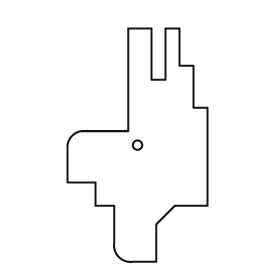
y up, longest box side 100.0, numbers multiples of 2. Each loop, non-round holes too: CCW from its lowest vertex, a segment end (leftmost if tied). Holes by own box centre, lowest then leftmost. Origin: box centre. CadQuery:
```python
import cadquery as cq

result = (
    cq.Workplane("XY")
    .moveTo(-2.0, -50.0)
    .lineTo(8.0, -50.0)
    .lineTo(8.0, -34.0)
    .lineTo(16.0, -26.0)
    .lineTo(30.0, -26.0)
    .lineTo(30.0, 16.0)
    .lineTo(24.0, 16.0)
    .lineTo(24.0, 34.0)
    .lineTo(18.0, 34.0)
    .lineTo(18.0, 50.0)
    .lineTo(12.0, 50.0)
    .lineTo(12.0, 28.0)
    .lineTo(6.0, 28.0)
    .lineTo(6.0, 50.0)
    .lineTo(-4.0, 50.0)
    .lineTo(-4.0, 6.0)
    .lineTo(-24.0, 6.0)
    .threePointArc((-28.0, 4.0), (-30.0, 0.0))
    .lineTo(-30.0, -16.0)
    .lineTo(-18.0, -16.0)
    .lineTo(-18.0, -26.0)
    .lineTo(-10.0, -26.0)
    .lineTo(-10.0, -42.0)
    .threePointArc((-8.0, -48.0), (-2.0, -50.0))
    .close()
    .moveTo(0.0, 0.0)
    .circle(2.0)
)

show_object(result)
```